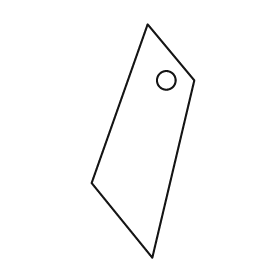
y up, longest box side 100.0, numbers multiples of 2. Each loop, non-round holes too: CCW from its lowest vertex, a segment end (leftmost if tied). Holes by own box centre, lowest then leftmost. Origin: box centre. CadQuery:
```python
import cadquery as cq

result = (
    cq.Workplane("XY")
    .moveTo(4.0, -50.0)
    .lineTo(22.0, 26.0)
    .lineTo(2.0, 50.0)
    .lineTo(-22.0, -18.0)
    .close()
    .moveTo(10.0, 26.0)
    .circle(4.0)
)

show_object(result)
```